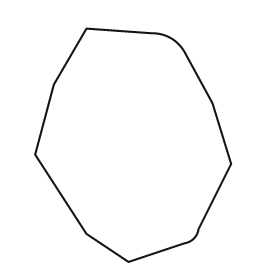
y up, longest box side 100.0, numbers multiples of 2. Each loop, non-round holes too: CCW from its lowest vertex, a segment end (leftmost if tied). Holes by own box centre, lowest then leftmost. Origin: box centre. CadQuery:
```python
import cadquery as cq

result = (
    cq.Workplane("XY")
    .moveTo(-2.0, -50.0)
    .lineTo(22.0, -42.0)
    .threePointArc((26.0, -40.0), (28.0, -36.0))
    .lineTo(42.0, -8.0)
    .lineTo(34.0, 18.0)
    .lineTo(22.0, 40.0)
    .threePointArc((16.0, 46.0), (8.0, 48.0))
    .lineTo(-20.0, 50.0)
    .lineTo(-34.0, 26.0)
    .lineTo(-42.0, -4.0)
    .lineTo(-20.0, -38.0)
    .close()
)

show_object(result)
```